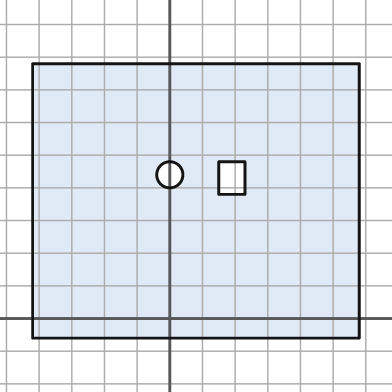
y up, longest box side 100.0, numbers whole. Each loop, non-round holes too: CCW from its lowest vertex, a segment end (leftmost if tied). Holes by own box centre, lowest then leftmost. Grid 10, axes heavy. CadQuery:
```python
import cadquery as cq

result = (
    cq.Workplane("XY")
    .moveTo(-42.0, -6.0)
    .lineTo(58.0, -6.0)
    .lineTo(58.0, 78.0)
    .lineTo(-42.0, 78.0)
    .close()
    .moveTo(15.0, 38.0)
    .lineTo(23.0, 38.0)
    .lineTo(23.0, 48.0)
    .lineTo(15.0, 48.0)
    .close()
    .moveTo(0.0, 44.0)
    .circle(4.0)
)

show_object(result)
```